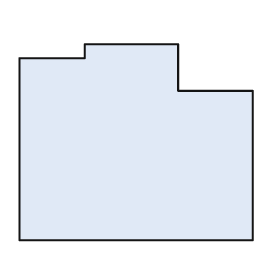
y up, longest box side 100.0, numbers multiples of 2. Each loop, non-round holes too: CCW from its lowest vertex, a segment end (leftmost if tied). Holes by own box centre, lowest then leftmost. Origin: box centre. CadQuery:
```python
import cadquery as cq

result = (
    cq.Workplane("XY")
    .moveTo(-50.0, -42.0)
    .lineTo(50.0, -42.0)
    .lineTo(50.0, 22.0)
    .lineTo(18.0, 22.0)
    .lineTo(18.0, 42.0)
    .lineTo(-22.0, 42.0)
    .lineTo(-22.0, 36.0)
    .lineTo(-50.0, 36.0)
    .close()
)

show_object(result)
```